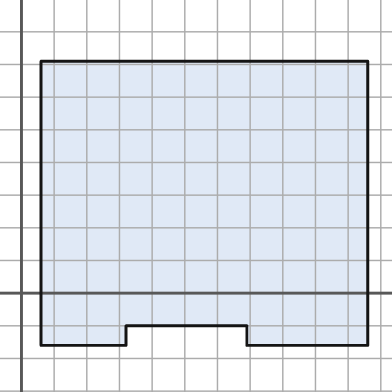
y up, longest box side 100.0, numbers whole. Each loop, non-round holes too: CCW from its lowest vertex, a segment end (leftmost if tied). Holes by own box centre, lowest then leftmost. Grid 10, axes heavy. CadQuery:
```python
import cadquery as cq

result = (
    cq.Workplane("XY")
    .moveTo(6.0, -16.0)
    .lineTo(32.0, -16.0)
    .lineTo(32.0, -10.0)
    .lineTo(69.0, -10.0)
    .lineTo(69.0, -16.0)
    .lineTo(106.0, -16.0)
    .lineTo(106.0, 71.0)
    .lineTo(6.0, 71.0)
    .close()
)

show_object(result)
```